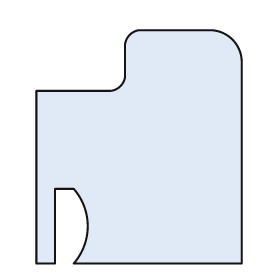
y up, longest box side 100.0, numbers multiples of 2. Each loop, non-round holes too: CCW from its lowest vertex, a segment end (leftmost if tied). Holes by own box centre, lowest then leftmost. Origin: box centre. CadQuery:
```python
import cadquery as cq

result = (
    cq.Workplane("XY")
    .moveTo(-44.0, -50.0)
    .lineTo(-36.0, -50.0)
    .lineTo(-36.0, -18.0)
    .lineTo(-28.0, -18.0)
    .threePointArc((-22.0, -34.0), (-28.0, -50.0))
    .lineTo(44.0, -50.0)
    .lineTo(44.0, 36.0)
    .threePointArc((40.0, 46.0), (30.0, 50.0))
    .lineTo(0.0, 50.0)
    .threePointArc((-4.0, 48.0), (-6.0, 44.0))
    .lineTo(-6.0, 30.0)
    .threePointArc((-8.0, 26.0), (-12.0, 24.0))
    .lineTo(-44.0, 24.0)
    .close()
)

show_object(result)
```